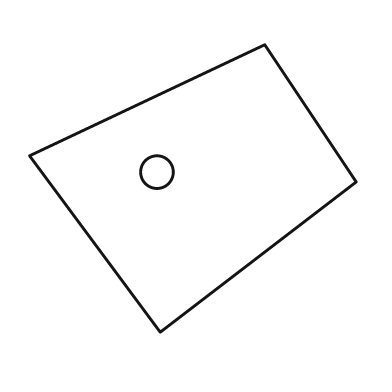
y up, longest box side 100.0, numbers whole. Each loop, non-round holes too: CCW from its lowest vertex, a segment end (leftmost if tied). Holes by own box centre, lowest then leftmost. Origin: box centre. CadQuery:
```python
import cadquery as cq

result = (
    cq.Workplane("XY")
    .moveTo(-10.0, -44.0)
    .lineTo(50.0, 2.0)
    .lineTo(22.0, 44.0)
    .lineTo(-50.0, 10.0)
    .close()
    .moveTo(-11.0, 5.0)
    .circle(5.0)
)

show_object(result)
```